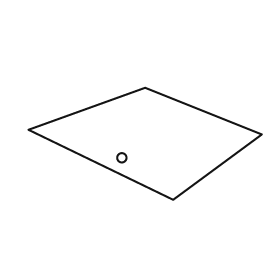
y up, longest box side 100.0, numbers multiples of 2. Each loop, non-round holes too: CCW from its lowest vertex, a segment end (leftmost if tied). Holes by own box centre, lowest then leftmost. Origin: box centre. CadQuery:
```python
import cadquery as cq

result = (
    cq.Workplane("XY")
    .moveTo(12.0, -24.0)
    .lineTo(50.0, 4.0)
    .lineTo(0.0, 24.0)
    .lineTo(-50.0, 6.0)
    .close()
    .moveTo(-10.0, -6.0)
    .circle(2.0)
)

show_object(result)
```